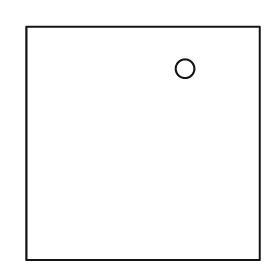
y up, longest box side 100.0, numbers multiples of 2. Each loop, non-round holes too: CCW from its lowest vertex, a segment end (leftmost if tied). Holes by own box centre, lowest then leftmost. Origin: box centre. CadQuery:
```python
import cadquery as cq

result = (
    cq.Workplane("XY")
    .moveTo(-50.0, -50.0)
    .lineTo(50.0, -50.0)
    .lineTo(50.0, 50.0)
    .lineTo(-50.0, 50.0)
    .close()
    .moveTo(18.0, 32.0)
    .circle(4.0)
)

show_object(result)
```